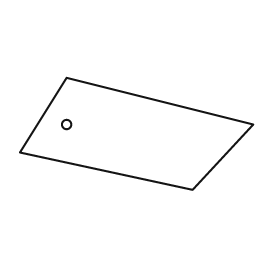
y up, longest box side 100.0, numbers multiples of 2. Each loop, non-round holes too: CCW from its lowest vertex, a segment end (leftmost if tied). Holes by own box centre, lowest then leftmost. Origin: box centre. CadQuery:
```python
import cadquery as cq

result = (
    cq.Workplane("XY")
    .moveTo(24.0, -24.0)
    .lineTo(50.0, 4.0)
    .lineTo(-30.0, 24.0)
    .lineTo(-50.0, -8.0)
    .close()
    .moveTo(-30.0, 4.0)
    .circle(2.0)
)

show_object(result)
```